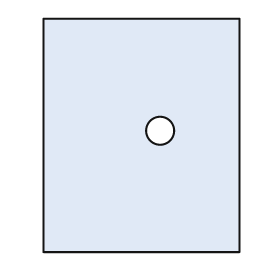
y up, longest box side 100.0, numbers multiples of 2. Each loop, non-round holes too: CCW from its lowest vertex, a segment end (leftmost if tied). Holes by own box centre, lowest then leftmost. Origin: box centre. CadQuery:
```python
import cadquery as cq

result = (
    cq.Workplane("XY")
    .moveTo(-42.0, -50.0)
    .lineTo(42.0, -50.0)
    .lineTo(42.0, 50.0)
    .lineTo(-42.0, 50.0)
    .close()
    .moveTo(8.0, 2.0)
    .circle(6.0)
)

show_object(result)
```